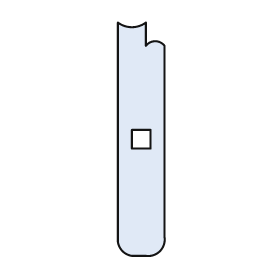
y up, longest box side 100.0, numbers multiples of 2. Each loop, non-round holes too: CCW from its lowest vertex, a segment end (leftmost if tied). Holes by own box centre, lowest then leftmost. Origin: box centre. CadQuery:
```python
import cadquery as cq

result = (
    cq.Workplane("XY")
    .moveTo(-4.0, -50.0)
    .lineTo(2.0, -50.0)
    .threePointArc((8.0, -48.0), (10.0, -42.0))
    .lineTo(10.0, 40.0)
    .threePointArc((6.0, 42.0), (2.0, 40.0))
    .lineTo(2.0, 50.0)
    .threePointArc((-4.0, 48.0), (-10.0, 50.0))
    .lineTo(-10.0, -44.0)
    .threePointArc((-8.0, -48.0), (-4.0, -50.0))
    .close()
    .moveTo(-4.0, -4.0)
    .lineTo(4.0, -4.0)
    .lineTo(4.0, 4.0)
    .lineTo(-4.0, 4.0)
    .close()
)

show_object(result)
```